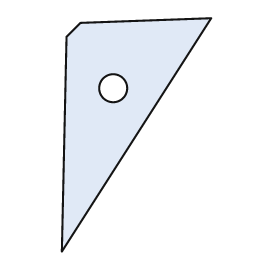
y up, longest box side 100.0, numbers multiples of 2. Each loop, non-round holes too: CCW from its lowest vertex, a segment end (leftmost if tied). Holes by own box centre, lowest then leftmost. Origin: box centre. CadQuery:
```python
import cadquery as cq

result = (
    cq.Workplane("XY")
    .moveTo(-32.0, -50.0)
    .lineTo(32.0, 50.0)
    .lineTo(-24.0, 48.0)
    .lineTo(-30.0, 42.0)
    .close()
    .moveTo(-10.0, 20.0)
    .circle(6.0)
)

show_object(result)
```